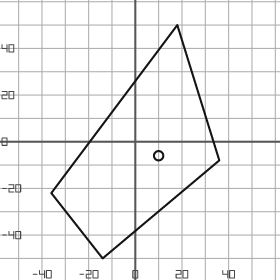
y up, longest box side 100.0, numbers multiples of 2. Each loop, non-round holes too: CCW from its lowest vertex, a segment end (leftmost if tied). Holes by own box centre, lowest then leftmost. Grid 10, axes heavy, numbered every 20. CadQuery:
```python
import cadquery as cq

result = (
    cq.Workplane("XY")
    .moveTo(-14.0, -50.0)
    .lineTo(36.0, -8.0)
    .lineTo(18.0, 50.0)
    .lineTo(-36.0, -22.0)
    .close()
    .moveTo(10.0, -6.0)
    .circle(2.0)
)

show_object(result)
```